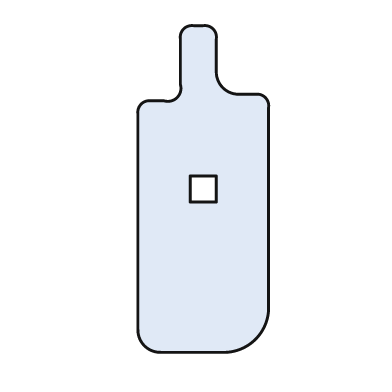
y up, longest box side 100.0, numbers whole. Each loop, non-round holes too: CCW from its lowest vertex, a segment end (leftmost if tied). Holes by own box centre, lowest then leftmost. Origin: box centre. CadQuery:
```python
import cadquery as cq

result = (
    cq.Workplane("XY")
    .moveTo(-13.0, -50.0)
    .lineTo(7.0, -50.0)
    .threePointArc((16.0, -46.0), (20.0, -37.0))
    .lineTo(20.0, 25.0)
    .threePointArc((19.0, 28.0), (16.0, 29.0))
    .lineTo(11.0, 29.0)
    .threePointArc((6.0, 31.0), (4.0, 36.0))
    .lineTo(4.0, 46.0)
    .threePointArc((3.0, 49.0), (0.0, 50.0))
    .lineTo(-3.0, 50.0)
    .threePointArc((-6.0, 49.0), (-7.0, 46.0))
    .lineTo(-7.0, 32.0)
    .threePointArc((-8.0, 28.0), (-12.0, 27.0))
    .lineTo(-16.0, 27.0)
    .threePointArc((-19.0, 26.0), (-20.0, 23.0))
    .lineTo(-20.0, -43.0)
    .threePointArc((-18.0, -48.0), (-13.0, -50.0))
    .close()
    .moveTo(-4.0, -4.0)
    .lineTo(4.0, -4.0)
    .lineTo(4.0, 4.0)
    .lineTo(-4.0, 4.0)
    .close()
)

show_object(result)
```